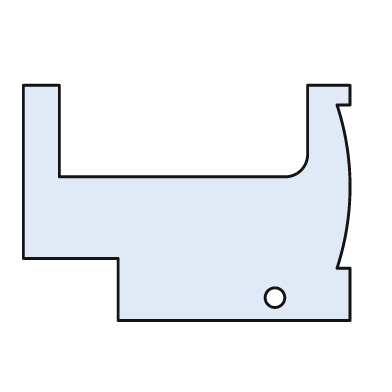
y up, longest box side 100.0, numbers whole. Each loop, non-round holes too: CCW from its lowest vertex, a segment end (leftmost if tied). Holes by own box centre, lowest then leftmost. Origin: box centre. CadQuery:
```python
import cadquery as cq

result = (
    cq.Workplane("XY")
    .moveTo(-21.0, -36.0)
    .lineTo(50.0, -36.0)
    .lineTo(50.0, -20.0)
    .lineTo(46.0, -20.0)
    .threePointArc((50.0, 5.0), (46.0, 30.0))
    .lineTo(50.0, 30.0)
    .lineTo(50.0, 36.0)
    .lineTo(37.0, 36.0)
    .lineTo(37.0, 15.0)
    .threePointArc((35.0, 10.0), (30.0, 8.0))
    .lineTo(-39.0, 8.0)
    .lineTo(-39.0, 36.0)
    .lineTo(-50.0, 36.0)
    .lineTo(-50.0, -17.0)
    .lineTo(-21.0, -17.0)
    .close()
    .moveTo(27.0, -29.0)
    .circle(3.0)
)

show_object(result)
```